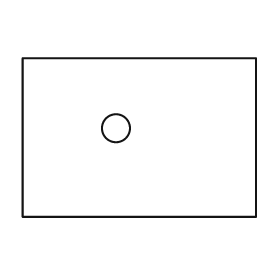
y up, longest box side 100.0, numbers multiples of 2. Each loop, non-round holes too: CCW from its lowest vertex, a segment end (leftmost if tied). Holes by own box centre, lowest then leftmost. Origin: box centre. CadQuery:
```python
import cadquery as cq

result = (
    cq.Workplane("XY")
    .moveTo(-50.0, -34.0)
    .lineTo(50.0, -34.0)
    .lineTo(50.0, 34.0)
    .lineTo(-50.0, 34.0)
    .close()
    .moveTo(-10.0, 4.0)
    .circle(6.0)
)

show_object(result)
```